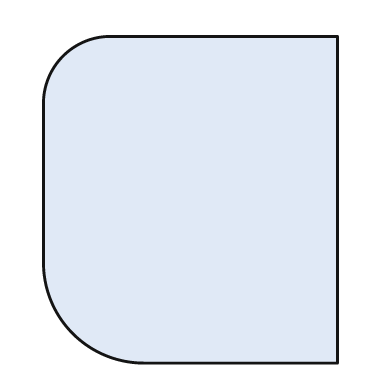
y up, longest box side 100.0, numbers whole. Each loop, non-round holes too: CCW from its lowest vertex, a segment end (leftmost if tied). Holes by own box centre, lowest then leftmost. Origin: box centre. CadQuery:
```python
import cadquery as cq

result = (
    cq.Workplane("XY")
    .moveTo(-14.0, -50.0)
    .lineTo(45.0, -50.0)
    .lineTo(45.0, 50.0)
    .lineTo(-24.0, 50.0)
    .threePointArc((-39.0, 44.0), (-45.0, 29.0))
    .lineTo(-45.0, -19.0)
    .threePointArc((-36.0, -41.0), (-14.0, -50.0))
    .close()
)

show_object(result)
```